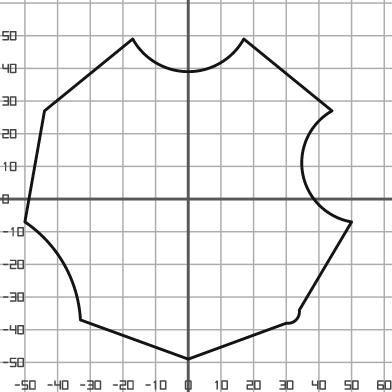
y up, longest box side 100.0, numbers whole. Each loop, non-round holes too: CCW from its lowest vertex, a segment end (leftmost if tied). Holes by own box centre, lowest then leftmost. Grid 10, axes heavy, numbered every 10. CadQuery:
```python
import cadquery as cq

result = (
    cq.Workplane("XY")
    .moveTo(0.0, -49.0)
    .lineTo(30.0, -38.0)
    .threePointArc((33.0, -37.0), (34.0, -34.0))
    .lineTo(50.0, -7.0)
    .threePointArc((35.0, 8.0), (44.0, 27.0))
    .lineTo(17.0, 49.0)
    .threePointArc((0.0, 39.0), (-17.0, 49.0))
    .lineTo(-44.0, 27.0)
    .lineTo(-50.0, -7.0)
    .threePointArc((-38.0, -20.0), (-33.0, -37.0))
    .close()
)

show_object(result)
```